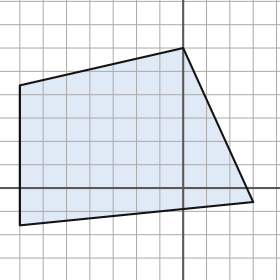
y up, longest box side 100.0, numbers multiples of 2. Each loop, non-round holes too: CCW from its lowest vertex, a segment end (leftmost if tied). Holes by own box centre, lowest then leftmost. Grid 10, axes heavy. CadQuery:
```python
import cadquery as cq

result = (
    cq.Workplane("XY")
    .moveTo(-70.0, -16.0)
    .lineTo(30.0, -6.0)
    .lineTo(0.0, 60.0)
    .lineTo(-70.0, 44.0)
    .close()
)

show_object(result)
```